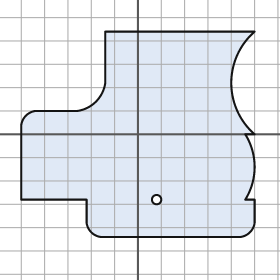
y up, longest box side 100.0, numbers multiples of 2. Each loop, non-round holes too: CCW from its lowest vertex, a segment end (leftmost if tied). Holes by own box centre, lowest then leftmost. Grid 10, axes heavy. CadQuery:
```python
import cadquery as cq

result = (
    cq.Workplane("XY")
    .moveTo(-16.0, -44.0)
    .lineTo(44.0, -44.0)
    .threePointArc((48.0, -42.0), (50.0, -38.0))
    .lineTo(50.0, -28.0)
    .lineTo(46.0, -28.0)
    .threePointArc((50.0, -14.0), (46.0, 0.0))
    .lineTo(50.0, 0.0)
    .threePointArc((40.0, 22.0), (50.0, 44.0))
    .lineTo(-14.0, 44.0)
    .lineTo(-14.0, 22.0)
    .threePointArc((-18.0, 14.0), (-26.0, 10.0))
    .lineTo(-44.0, 10.0)
    .threePointArc((-48.0, 8.0), (-50.0, 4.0))
    .lineTo(-50.0, -28.0)
    .lineTo(-22.0, -28.0)
    .lineTo(-22.0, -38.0)
    .threePointArc((-20.0, -42.0), (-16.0, -44.0))
    .close()
    .moveTo(8.0, -28.0)
    .circle(2.0)
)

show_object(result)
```